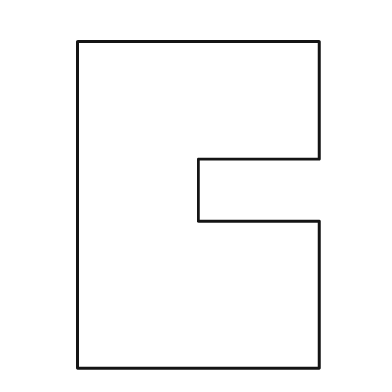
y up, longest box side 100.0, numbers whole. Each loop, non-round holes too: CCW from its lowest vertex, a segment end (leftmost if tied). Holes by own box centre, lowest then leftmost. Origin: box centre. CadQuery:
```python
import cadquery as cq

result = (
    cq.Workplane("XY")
    .moveTo(-37.0, -50.0)
    .lineTo(37.0, -50.0)
    .lineTo(37.0, -5.0)
    .lineTo(0.0, -5.0)
    .lineTo(0.0, 14.0)
    .lineTo(37.0, 14.0)
    .lineTo(37.0, 50.0)
    .lineTo(-37.0, 50.0)
    .close()
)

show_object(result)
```